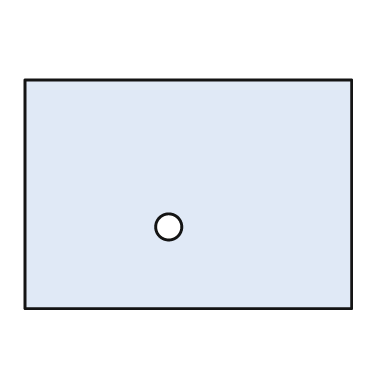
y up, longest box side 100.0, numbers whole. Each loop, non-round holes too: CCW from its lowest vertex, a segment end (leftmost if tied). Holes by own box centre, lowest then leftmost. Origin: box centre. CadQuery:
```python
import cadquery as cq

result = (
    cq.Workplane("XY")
    .moveTo(-50.0, -35.0)
    .lineTo(50.0, -35.0)
    .lineTo(50.0, 35.0)
    .lineTo(-50.0, 35.0)
    .close()
    .moveTo(-6.0, -10.0)
    .circle(4.0)
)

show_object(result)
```